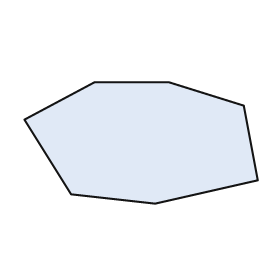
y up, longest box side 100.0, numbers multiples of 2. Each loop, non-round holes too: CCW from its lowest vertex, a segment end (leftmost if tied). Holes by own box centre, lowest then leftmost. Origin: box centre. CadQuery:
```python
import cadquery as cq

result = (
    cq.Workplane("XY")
    .moveTo(6.0, -26.0)
    .lineTo(50.0, -16.0)
    .lineTo(44.0, 16.0)
    .lineTo(12.0, 26.0)
    .lineTo(-20.0, 26.0)
    .lineTo(-50.0, 10.0)
    .lineTo(-30.0, -22.0)
    .close()
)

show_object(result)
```